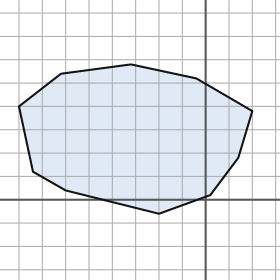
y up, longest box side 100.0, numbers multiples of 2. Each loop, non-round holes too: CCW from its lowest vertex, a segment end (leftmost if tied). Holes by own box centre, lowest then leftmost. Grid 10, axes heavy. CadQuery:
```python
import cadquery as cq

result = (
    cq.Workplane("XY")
    .moveTo(-20.0, -6.0)
    .lineTo(2.0, 2.0)
    .lineTo(14.0, 18.0)
    .lineTo(20.0, 38.0)
    .lineTo(-4.0, 52.0)
    .lineTo(-32.0, 58.0)
    .lineTo(-62.0, 54.0)
    .lineTo(-80.0, 40.0)
    .lineTo(-74.0, 12.0)
    .lineTo(-60.0, 4.0)
    .close()
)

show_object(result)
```